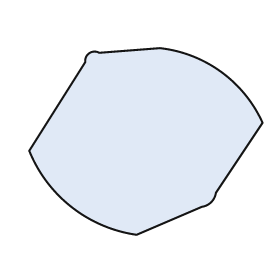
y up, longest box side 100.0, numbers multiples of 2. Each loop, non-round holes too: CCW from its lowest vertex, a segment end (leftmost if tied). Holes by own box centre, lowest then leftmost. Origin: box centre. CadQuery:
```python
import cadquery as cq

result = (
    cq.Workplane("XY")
    .moveTo(-4.0, -40.0)
    .lineTo(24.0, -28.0)
    .threePointArc((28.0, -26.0), (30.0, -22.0))
    .lineTo(50.0, 8.0)
    .threePointArc((32.0, 30.0), (6.0, 40.0))
    .lineTo(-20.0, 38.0)
    .threePointArc((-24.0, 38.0), (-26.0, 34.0))
    .lineTo(-50.0, -4.0)
    .threePointArc((-32.0, -28.0), (-4.0, -40.0))
    .close()
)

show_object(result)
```